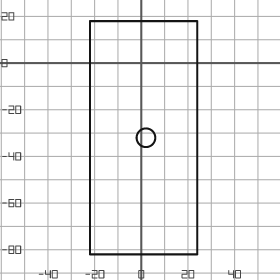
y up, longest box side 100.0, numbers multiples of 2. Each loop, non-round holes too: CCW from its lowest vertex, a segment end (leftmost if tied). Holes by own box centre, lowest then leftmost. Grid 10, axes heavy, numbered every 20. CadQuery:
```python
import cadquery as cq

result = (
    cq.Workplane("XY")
    .moveTo(-22.0, -82.0)
    .lineTo(24.0, -82.0)
    .lineTo(24.0, 18.0)
    .lineTo(-22.0, 18.0)
    .close()
    .moveTo(2.0, -32.0)
    .circle(4.0)
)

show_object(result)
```